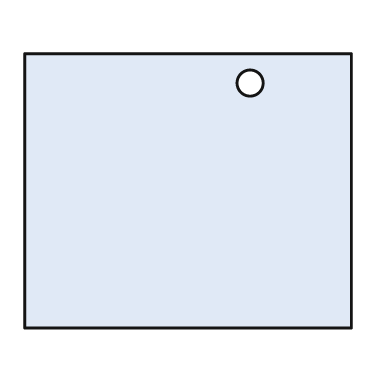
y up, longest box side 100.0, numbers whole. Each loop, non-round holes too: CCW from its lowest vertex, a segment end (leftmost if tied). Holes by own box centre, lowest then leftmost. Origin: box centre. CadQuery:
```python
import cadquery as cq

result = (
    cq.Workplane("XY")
    .moveTo(-50.0, -42.0)
    .lineTo(50.0, -42.0)
    .lineTo(50.0, 42.0)
    .lineTo(-50.0, 42.0)
    .close()
    .moveTo(19.0, 33.0)
    .circle(4.0)
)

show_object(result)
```